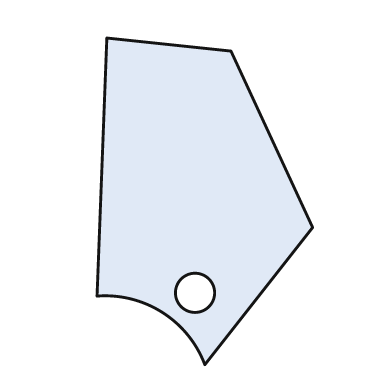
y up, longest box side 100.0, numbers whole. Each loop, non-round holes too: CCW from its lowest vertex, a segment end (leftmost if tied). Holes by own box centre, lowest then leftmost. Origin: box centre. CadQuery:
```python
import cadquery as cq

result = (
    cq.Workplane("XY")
    .moveTo(0.0, -50.0)
    .lineTo(33.0, -8.0)
    .lineTo(8.0, 46.0)
    .lineTo(-30.0, 50.0)
    .lineTo(-33.0, -29.0)
    .threePointArc((-13.0, -34.0), (0.0, -50.0))
    .close()
    .moveTo(-3.0, -28.0)
    .circle(6.0)
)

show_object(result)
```